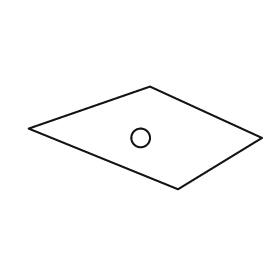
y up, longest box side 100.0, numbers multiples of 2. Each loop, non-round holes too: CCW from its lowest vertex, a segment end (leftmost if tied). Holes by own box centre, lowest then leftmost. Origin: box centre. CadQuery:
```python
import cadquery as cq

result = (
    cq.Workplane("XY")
    .moveTo(14.0, -22.0)
    .lineTo(50.0, 0.0)
    .lineTo(2.0, 22.0)
    .lineTo(-50.0, 4.0)
    .close()
    .moveTo(-2.0, 0.0)
    .circle(4.0)
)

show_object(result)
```